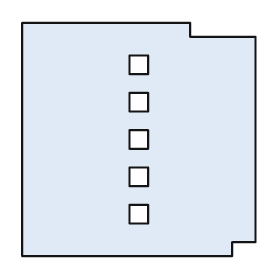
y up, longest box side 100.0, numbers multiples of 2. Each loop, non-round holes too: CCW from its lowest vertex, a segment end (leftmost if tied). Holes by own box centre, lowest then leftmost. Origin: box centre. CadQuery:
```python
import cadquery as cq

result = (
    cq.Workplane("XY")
    .moveTo(-50.0, -50.0)
    .lineTo(40.0, -50.0)
    .lineTo(40.0, -44.0)
    .lineTo(50.0, -44.0)
    .lineTo(50.0, 44.0)
    .lineTo(22.0, 44.0)
    .lineTo(22.0, 50.0)
    .lineTo(-50.0, 50.0)
    .close()
    .moveTo(-4.0, -36.0)
    .lineTo(4.0, -36.0)
    .lineTo(4.0, -28.0)
    .lineTo(-4.0, -28.0)
    .close()
    .moveTo(-4.0, -20.0)
    .lineTo(4.0, -20.0)
    .lineTo(4.0, -12.0)
    .lineTo(-4.0, -12.0)
    .close()
    .moveTo(-4.0, -4.0)
    .lineTo(4.0, -4.0)
    .lineTo(4.0, 4.0)
    .lineTo(-4.0, 4.0)
    .close()
    .moveTo(-4.0, 12.0)
    .lineTo(4.0, 12.0)
    .lineTo(4.0, 20.0)
    .lineTo(-4.0, 20.0)
    .close()
    .moveTo(-4.0, 28.0)
    .lineTo(4.0, 28.0)
    .lineTo(4.0, 36.0)
    .lineTo(-4.0, 36.0)
    .close()
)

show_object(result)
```